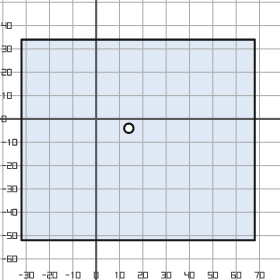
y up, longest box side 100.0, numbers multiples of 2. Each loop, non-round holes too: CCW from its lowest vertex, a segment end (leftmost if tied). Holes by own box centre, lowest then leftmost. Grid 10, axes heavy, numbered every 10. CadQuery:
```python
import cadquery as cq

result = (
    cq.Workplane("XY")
    .moveTo(-32.0, -52.0)
    .lineTo(68.0, -52.0)
    .lineTo(68.0, 34.0)
    .lineTo(-32.0, 34.0)
    .close()
    .moveTo(14.0, -4.0)
    .circle(2.0)
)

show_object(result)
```